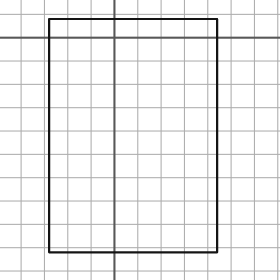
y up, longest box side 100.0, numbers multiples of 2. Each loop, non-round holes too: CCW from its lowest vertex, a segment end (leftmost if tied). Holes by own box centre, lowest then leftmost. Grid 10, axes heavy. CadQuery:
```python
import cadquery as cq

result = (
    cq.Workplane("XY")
    .moveTo(-28.0, -92.0)
    .lineTo(44.0, -92.0)
    .lineTo(44.0, 8.0)
    .lineTo(-28.0, 8.0)
    .close()
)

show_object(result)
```